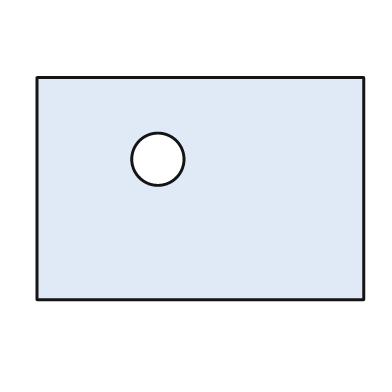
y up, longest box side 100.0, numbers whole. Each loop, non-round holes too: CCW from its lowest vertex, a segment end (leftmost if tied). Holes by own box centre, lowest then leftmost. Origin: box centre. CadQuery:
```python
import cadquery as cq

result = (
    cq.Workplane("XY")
    .moveTo(-50.0, -34.0)
    .lineTo(50.0, -34.0)
    .lineTo(50.0, 34.0)
    .lineTo(-50.0, 34.0)
    .close()
    .moveTo(-13.0, 9.0)
    .circle(8.0)
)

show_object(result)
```